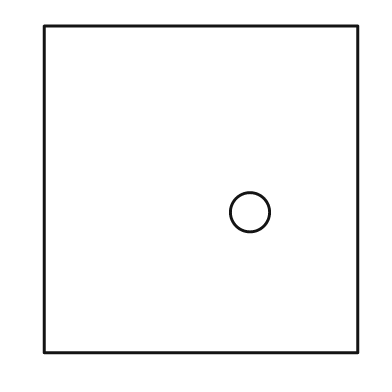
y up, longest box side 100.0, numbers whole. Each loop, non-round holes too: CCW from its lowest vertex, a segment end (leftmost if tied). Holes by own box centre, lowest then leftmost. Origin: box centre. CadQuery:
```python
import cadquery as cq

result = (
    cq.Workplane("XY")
    .moveTo(-48.0, -50.0)
    .lineTo(48.0, -50.0)
    .lineTo(48.0, 50.0)
    .lineTo(-48.0, 50.0)
    .close()
    .moveTo(15.0, -7.0)
    .circle(6.0)
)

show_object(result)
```